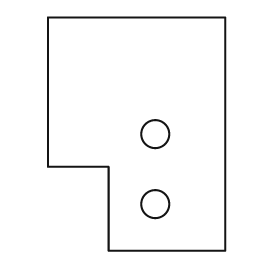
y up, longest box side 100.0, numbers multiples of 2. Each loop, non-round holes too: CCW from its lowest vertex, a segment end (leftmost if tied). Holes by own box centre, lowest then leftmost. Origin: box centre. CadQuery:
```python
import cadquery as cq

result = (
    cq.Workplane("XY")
    .moveTo(-12.0, -50.0)
    .lineTo(38.0, -50.0)
    .lineTo(38.0, 50.0)
    .lineTo(-38.0, 50.0)
    .lineTo(-38.0, -14.0)
    .lineTo(-12.0, -14.0)
    .close()
    .moveTo(8.0, -30.0)
    .circle(6.0)
    .moveTo(8.0, 0.0)
    .circle(6.0)
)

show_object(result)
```